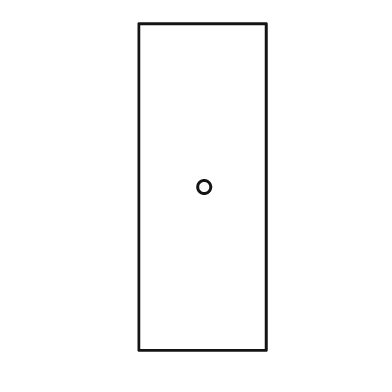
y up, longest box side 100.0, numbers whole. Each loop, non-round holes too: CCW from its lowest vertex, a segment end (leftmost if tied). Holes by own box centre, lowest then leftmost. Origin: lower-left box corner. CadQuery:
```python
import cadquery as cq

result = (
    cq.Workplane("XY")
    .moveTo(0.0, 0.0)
    .lineTo(39.0, 0.0)
    .lineTo(39.0, 100.0)
    .lineTo(0.0, 100.0)
    .close()
    .moveTo(20.0, 50.0)
    .circle(2.0)
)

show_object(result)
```